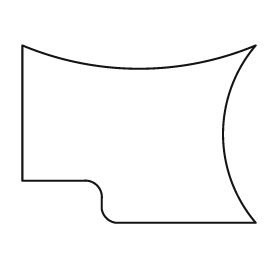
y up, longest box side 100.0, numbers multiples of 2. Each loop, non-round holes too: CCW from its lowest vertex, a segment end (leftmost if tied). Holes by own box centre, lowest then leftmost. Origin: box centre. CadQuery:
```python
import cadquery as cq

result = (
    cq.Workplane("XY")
    .moveTo(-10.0, -38.0)
    .lineTo(50.0, -38.0)
    .threePointArc((36.0, 0.0), (50.0, 38.0))
    .threePointArc((0.0, 28.0), (-50.0, 38.0))
    .lineTo(-50.0, -20.0)
    .lineTo(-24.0, -20.0)
    .threePointArc((-18.0, -22.0), (-16.0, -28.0))
    .lineTo(-16.0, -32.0)
    .threePointArc((-14.0, -36.0), (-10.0, -38.0))
    .close()
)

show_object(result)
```